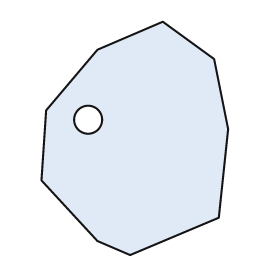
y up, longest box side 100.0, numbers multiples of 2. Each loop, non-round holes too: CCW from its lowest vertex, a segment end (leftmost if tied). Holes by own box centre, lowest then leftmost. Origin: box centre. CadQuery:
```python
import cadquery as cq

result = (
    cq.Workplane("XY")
    .moveTo(-2.0, -50.0)
    .lineTo(36.0, -34.0)
    .lineTo(40.0, 4.0)
    .lineTo(34.0, 34.0)
    .lineTo(12.0, 50.0)
    .lineTo(-16.0, 38.0)
    .lineTo(-38.0, 12.0)
    .lineTo(-40.0, -18.0)
    .lineTo(-16.0, -44.0)
    .close()
    .moveTo(-20.0, 8.0)
    .circle(6.0)
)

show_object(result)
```